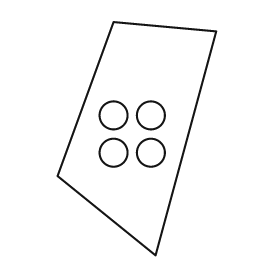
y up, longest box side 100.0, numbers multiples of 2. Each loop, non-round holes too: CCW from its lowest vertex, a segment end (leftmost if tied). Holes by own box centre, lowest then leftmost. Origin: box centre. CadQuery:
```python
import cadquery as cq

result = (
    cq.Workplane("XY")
    .moveTo(8.0, -50.0)
    .lineTo(34.0, 46.0)
    .lineTo(-10.0, 50.0)
    .lineTo(-34.0, -16.0)
    .close()
    .moveTo(-10.0, -6.0)
    .circle(6.0)
    .moveTo(6.0, -6.0)
    .circle(6.0)
    .moveTo(-10.0, 10.0)
    .circle(6.0)
    .moveTo(6.0, 10.0)
    .circle(6.0)
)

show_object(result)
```